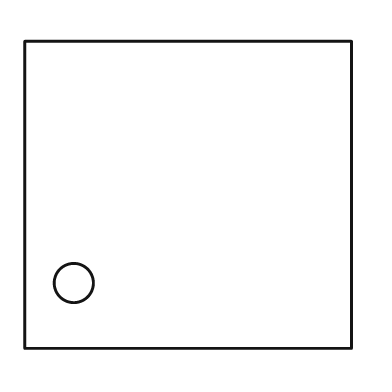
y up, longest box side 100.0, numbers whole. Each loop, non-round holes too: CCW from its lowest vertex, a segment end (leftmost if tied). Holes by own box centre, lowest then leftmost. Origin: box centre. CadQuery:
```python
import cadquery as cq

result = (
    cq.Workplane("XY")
    .moveTo(-50.0, -47.0)
    .lineTo(50.0, -47.0)
    .lineTo(50.0, 47.0)
    .lineTo(-50.0, 47.0)
    .close()
    .moveTo(-35.0, -27.0)
    .circle(6.0)
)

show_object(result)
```